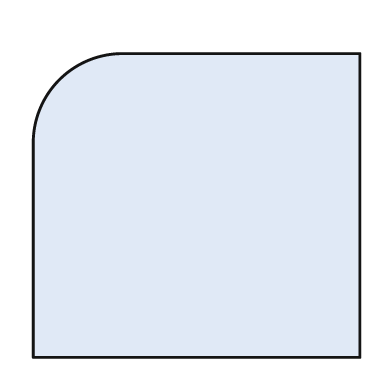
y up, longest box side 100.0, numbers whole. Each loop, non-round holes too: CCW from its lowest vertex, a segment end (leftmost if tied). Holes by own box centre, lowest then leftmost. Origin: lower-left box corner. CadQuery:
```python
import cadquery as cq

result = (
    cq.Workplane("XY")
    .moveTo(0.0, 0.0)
    .lineTo(100.0, 0.0)
    .lineTo(100.0, 93.0)
    .lineTo(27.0, 93.0)
    .threePointArc((8.0, 85.0), (0.0, 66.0))
    .close()
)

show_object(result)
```